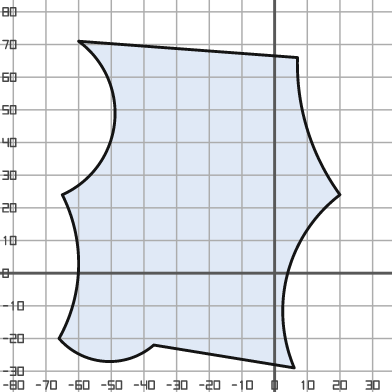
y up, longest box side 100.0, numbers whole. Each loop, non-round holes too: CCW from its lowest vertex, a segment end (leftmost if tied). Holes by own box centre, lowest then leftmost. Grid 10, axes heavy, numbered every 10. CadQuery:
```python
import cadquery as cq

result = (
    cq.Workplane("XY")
    .moveTo(6.0, -29.0)
    .threePointArc((4.0, 0.0), (20.0, 24.0))
    .threePointArc((10.0, 44.0), (7.0, 66.0))
    .lineTo(-60.0, 71.0)
    .threePointArc((-49.0, 46.0), (-65.0, 24.0))
    .threePointArc((-60.0, 2.0), (-66.0, -20.0))
    .threePointArc((-52.0, -27.0), (-37.0, -22.0))
    .close()
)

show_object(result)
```